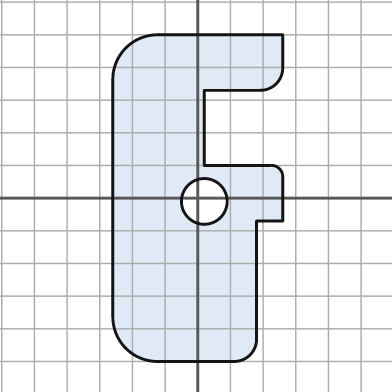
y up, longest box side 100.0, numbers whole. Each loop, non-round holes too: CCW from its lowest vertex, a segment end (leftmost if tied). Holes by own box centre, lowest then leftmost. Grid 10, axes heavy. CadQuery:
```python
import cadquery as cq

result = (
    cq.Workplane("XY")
    .moveTo(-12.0, -50.0)
    .lineTo(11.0, -50.0)
    .threePointArc((16.0, -48.0), (18.0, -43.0))
    .lineTo(18.0, -7.0)
    .lineTo(26.0, -7.0)
    .lineTo(26.0, 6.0)
    .threePointArc((25.0, 9.0), (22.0, 10.0))
    .lineTo(2.0, 10.0)
    .lineTo(2.0, 33.0)
    .lineTo(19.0, 33.0)
    .threePointArc((24.0, 35.0), (26.0, 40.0))
    .lineTo(26.0, 50.0)
    .lineTo(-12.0, 50.0)
    .threePointArc((-22.0, 46.0), (-26.0, 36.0))
    .lineTo(-26.0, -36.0)
    .threePointArc((-22.0, -46.0), (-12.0, -50.0))
    .close()
    .moveTo(2.0, -1.0)
    .circle(7.0)
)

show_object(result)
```